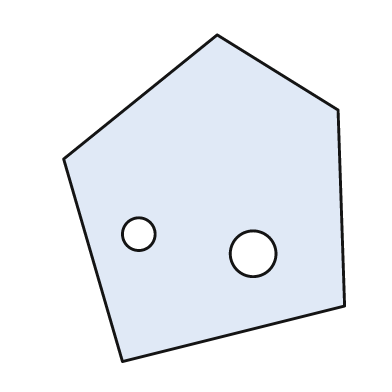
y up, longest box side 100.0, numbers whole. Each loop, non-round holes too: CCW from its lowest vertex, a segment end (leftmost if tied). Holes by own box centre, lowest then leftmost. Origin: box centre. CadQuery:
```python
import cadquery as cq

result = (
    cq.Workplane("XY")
    .moveTo(-25.0, -50.0)
    .lineTo(43.0, -33.0)
    .lineTo(41.0, 27.0)
    .lineTo(4.0, 50.0)
    .lineTo(-43.0, 12.0)
    .close()
    .moveTo(15.0, -17.0)
    .circle(7.0)
    .moveTo(-20.0, -11.0)
    .circle(5.0)
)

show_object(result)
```